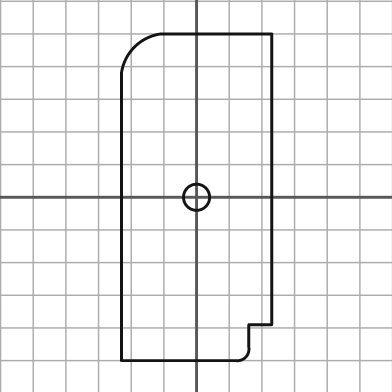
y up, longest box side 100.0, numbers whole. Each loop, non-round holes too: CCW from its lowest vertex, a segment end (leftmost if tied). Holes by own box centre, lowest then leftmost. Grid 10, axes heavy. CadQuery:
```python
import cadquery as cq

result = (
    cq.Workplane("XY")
    .moveTo(-23.0, -50.0)
    .lineTo(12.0, -50.0)
    .threePointArc((15.0, -49.0), (16.0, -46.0))
    .lineTo(16.0, -39.0)
    .lineTo(23.0, -39.0)
    .lineTo(23.0, 50.0)
    .lineTo(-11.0, 50.0)
    .threePointArc((-19.0, 46.0), (-23.0, 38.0))
    .close()
    .moveTo(0.0, 0.0)
    .circle(4.0)
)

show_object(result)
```